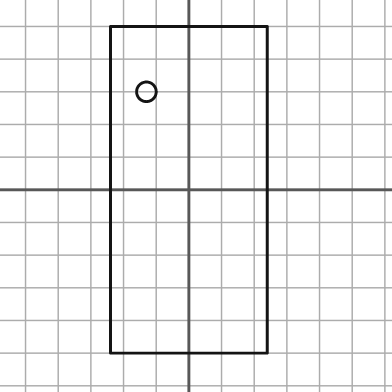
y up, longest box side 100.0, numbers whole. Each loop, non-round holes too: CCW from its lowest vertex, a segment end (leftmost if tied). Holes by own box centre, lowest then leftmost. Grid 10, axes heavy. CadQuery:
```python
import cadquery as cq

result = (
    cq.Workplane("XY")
    .moveTo(-24.0, -50.0)
    .lineTo(24.0, -50.0)
    .lineTo(24.0, 50.0)
    .lineTo(-24.0, 50.0)
    .close()
    .moveTo(-13.0, 30.0)
    .circle(3.0)
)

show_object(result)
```